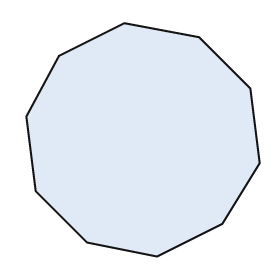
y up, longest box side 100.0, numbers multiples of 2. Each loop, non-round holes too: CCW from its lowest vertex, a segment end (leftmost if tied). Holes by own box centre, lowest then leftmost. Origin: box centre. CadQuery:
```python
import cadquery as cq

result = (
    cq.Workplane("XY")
    .moveTo(6.0, -50.0)
    .lineTo(34.0, -36.0)
    .lineTo(50.0, -10.0)
    .lineTo(46.0, 22.0)
    .lineTo(24.0, 44.0)
    .lineTo(-8.0, 50.0)
    .lineTo(-36.0, 36.0)
    .lineTo(-50.0, 10.0)
    .lineTo(-46.0, -22.0)
    .lineTo(-24.0, -44.0)
    .close()
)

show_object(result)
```